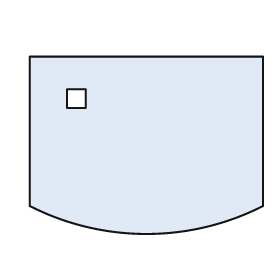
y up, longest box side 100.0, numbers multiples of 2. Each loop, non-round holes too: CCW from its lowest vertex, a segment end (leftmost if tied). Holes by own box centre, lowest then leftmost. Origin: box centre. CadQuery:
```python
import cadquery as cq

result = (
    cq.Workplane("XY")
    .moveTo(-50.0, -26.0)
    .threePointArc((0.0, -38.0), (50.0, -26.0))
    .lineTo(50.0, 38.0)
    .lineTo(-50.0, 38.0)
    .close()
    .moveTo(-34.0, 16.0)
    .lineTo(-26.0, 16.0)
    .lineTo(-26.0, 24.0)
    .lineTo(-34.0, 24.0)
    .close()
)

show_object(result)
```